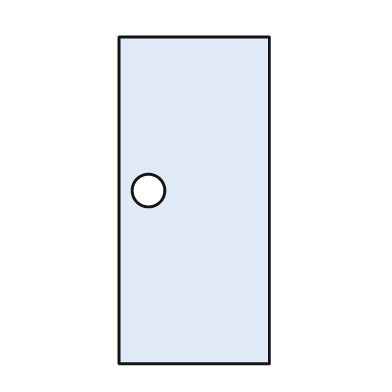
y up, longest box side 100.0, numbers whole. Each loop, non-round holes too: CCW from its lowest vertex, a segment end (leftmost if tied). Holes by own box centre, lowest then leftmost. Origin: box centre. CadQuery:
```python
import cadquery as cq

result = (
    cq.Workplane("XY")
    .moveTo(-23.0, -50.0)
    .lineTo(23.0, -50.0)
    .lineTo(23.0, 50.0)
    .lineTo(-23.0, 50.0)
    .close()
    .moveTo(-14.0, 3.0)
    .circle(5.0)
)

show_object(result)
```